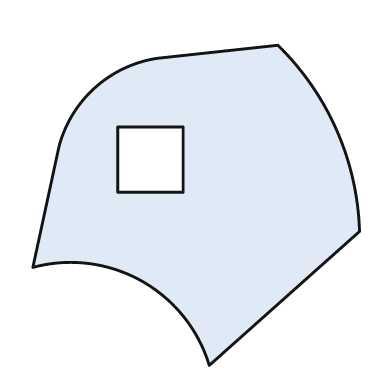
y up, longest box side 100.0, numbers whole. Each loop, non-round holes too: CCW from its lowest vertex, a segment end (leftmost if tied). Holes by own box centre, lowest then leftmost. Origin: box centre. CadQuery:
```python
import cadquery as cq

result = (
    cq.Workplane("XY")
    .moveTo(4.0, -49.0)
    .lineTo(50.0, -8.0)
    .threePointArc((43.0, 23.0), (25.0, 49.0))
    .lineTo(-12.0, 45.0)
    .threePointArc((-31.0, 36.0), (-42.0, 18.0))
    .lineTo(-50.0, -19.0)
    .threePointArc((-17.0, -23.0), (4.0, -49.0))
    .close()
    .moveTo(-24.0, 4.0)
    .lineTo(-4.0, 4.0)
    .lineTo(-4.0, 24.0)
    .lineTo(-24.0, 24.0)
    .close()
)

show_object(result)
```